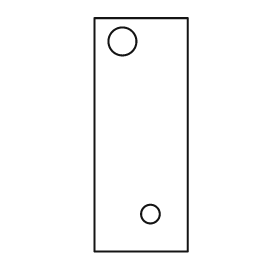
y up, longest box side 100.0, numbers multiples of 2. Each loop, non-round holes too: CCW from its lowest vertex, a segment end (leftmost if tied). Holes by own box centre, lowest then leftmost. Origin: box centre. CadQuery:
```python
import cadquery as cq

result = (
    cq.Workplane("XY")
    .moveTo(-20.0, -50.0)
    .lineTo(20.0, -50.0)
    .lineTo(20.0, 50.0)
    .lineTo(-20.0, 50.0)
    .close()
    .moveTo(4.0, -34.0)
    .circle(4.0)
    .moveTo(-8.0, 40.0)
    .circle(6.0)
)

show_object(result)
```